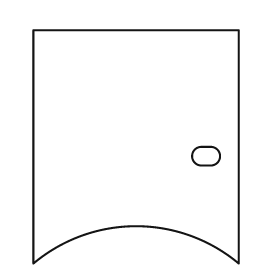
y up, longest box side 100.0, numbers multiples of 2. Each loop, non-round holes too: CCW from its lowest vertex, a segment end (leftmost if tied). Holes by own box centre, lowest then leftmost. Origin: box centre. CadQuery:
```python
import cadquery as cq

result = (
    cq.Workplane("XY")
    .moveTo(-44.0, -50.0)
    .threePointArc((0.0, -34.0), (44.0, -50.0))
    .lineTo(44.0, 50.0)
    .lineTo(-44.0, 50.0)
    .close()
    .moveTo(28.0, -8.0)
    .lineTo(32.0, -8.0)
    .threePointArc((36.0, -4.0), (32.0, 0.0))
    .lineTo(28.0, 0.0)
    .threePointArc((24.0, -4.0), (28.0, -8.0))
    .close()
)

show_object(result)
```